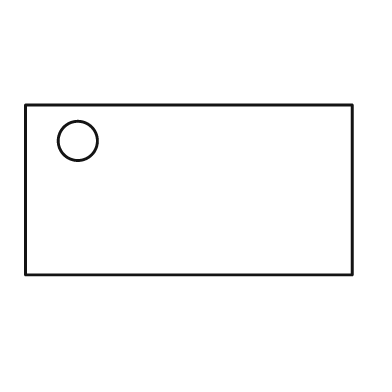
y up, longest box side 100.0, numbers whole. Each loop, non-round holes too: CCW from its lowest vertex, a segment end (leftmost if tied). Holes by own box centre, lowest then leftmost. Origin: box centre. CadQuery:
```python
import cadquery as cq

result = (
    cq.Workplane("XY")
    .moveTo(-50.0, -26.0)
    .lineTo(50.0, -26.0)
    .lineTo(50.0, 26.0)
    .lineTo(-50.0, 26.0)
    .close()
    .moveTo(-34.0, 15.0)
    .circle(6.0)
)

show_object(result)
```